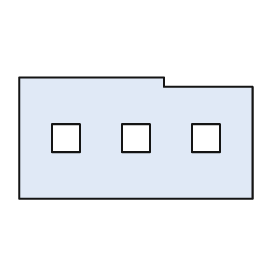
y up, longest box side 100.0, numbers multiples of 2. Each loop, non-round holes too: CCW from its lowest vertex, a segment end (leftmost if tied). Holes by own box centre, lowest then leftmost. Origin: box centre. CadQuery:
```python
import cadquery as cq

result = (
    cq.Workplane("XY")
    .moveTo(-50.0, -26.0)
    .lineTo(50.0, -26.0)
    .lineTo(50.0, 22.0)
    .lineTo(12.0, 22.0)
    .lineTo(12.0, 26.0)
    .lineTo(-50.0, 26.0)
    .close()
    .moveTo(-36.0, -6.0)
    .lineTo(-24.0, -6.0)
    .lineTo(-24.0, 6.0)
    .lineTo(-36.0, 6.0)
    .close()
    .moveTo(-6.0, -6.0)
    .lineTo(6.0, -6.0)
    .lineTo(6.0, 6.0)
    .lineTo(-6.0, 6.0)
    .close()
    .moveTo(24.0, -6.0)
    .lineTo(36.0, -6.0)
    .lineTo(36.0, 6.0)
    .lineTo(24.0, 6.0)
    .close()
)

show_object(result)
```